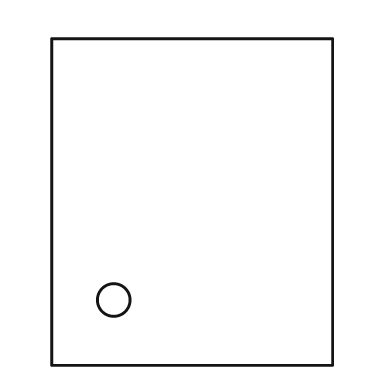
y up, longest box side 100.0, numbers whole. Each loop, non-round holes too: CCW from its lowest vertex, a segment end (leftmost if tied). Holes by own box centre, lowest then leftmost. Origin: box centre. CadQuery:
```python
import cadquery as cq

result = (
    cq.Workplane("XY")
    .moveTo(-43.0, -50.0)
    .lineTo(43.0, -50.0)
    .lineTo(43.0, 50.0)
    .lineTo(-43.0, 50.0)
    .close()
    .moveTo(-24.0, -30.0)
    .circle(5.0)
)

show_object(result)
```